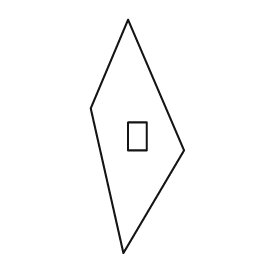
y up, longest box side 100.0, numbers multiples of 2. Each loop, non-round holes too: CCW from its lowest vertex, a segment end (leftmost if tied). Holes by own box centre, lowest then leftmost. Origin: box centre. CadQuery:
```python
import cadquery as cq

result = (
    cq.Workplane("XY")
    .moveTo(-6.0, -50.0)
    .lineTo(20.0, -6.0)
    .lineTo(-4.0, 50.0)
    .lineTo(-20.0, 12.0)
    .close()
    .moveTo(-4.0, -6.0)
    .lineTo(4.0, -6.0)
    .lineTo(4.0, 6.0)
    .lineTo(-4.0, 6.0)
    .close()
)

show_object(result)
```